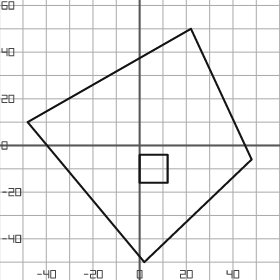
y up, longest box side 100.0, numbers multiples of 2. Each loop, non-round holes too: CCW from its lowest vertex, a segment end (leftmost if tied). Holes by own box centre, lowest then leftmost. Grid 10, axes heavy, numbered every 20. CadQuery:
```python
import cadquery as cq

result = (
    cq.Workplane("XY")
    .moveTo(2.0, -50.0)
    .lineTo(48.0, -6.0)
    .lineTo(22.0, 50.0)
    .lineTo(-48.0, 10.0)
    .close()
    .moveTo(0.0, -16.0)
    .lineTo(12.0, -16.0)
    .lineTo(12.0, -4.0)
    .lineTo(0.0, -4.0)
    .close()
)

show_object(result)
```